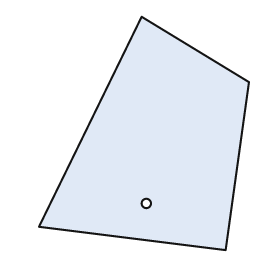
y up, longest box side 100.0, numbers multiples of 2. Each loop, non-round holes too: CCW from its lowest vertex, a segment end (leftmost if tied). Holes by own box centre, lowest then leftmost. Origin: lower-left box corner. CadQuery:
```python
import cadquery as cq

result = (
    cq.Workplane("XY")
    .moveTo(80.0, 0.0)
    .lineTo(90.0, 72.0)
    .lineTo(44.0, 100.0)
    .lineTo(0.0, 10.0)
    .close()
    .moveTo(46.0, 20.0)
    .circle(2.0)
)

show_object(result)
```